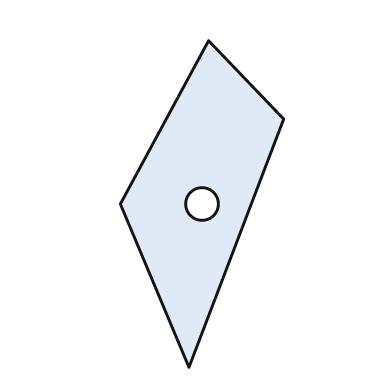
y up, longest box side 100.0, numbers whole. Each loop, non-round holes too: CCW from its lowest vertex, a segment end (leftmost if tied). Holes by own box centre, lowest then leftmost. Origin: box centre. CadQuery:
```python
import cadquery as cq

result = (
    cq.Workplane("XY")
    .moveTo(-4.0, -50.0)
    .lineTo(25.0, 26.0)
    .lineTo(2.0, 50.0)
    .lineTo(-25.0, 0.0)
    .close()
    .moveTo(0.0, 0.0)
    .circle(5.0)
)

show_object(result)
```